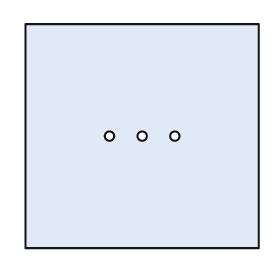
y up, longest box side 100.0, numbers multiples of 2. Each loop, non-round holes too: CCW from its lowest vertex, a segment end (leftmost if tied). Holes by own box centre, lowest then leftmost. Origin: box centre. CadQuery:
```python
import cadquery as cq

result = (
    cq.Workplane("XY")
    .moveTo(-50.0, -48.0)
    .lineTo(50.0, -48.0)
    .lineTo(50.0, 48.0)
    .lineTo(-50.0, 48.0)
    .close()
    .moveTo(-14.0, 0.0)
    .circle(2.0)
    .moveTo(0.0, 0.0)
    .circle(2.0)
    .moveTo(14.0, 0.0)
    .circle(2.0)
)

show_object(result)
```